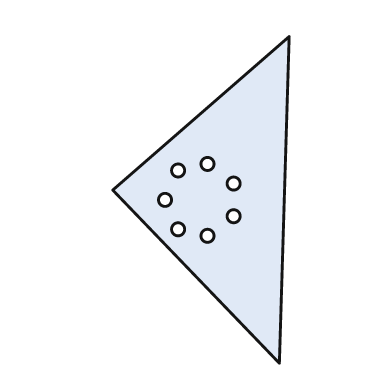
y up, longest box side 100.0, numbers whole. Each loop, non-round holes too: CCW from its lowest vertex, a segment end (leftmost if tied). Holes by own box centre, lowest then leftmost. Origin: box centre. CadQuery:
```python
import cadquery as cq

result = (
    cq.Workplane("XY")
    .moveTo(24.0, -50.0)
    .lineTo(27.0, 50.0)
    .lineTo(-27.0, 3.0)
    .close()
    .moveTo(2.0, -11.0)
    .circle(2.0)
    .moveTo(-7.0, -9.0)
    .circle(2.0)
    .moveTo(10.0, -5.0)
    .circle(2.0)
    .moveTo(-11.0, 0.0)
    .circle(2.0)
    .moveTo(10.0, 5.0)
    .circle(2.0)
    .moveTo(-7.0, 9.0)
    .circle(2.0)
    .moveTo(2.0, 11.0)
    .circle(2.0)
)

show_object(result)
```